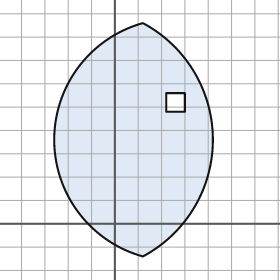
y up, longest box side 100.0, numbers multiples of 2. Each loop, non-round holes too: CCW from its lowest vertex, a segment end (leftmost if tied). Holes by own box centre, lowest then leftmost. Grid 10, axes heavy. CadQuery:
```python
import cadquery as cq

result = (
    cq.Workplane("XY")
    .moveTo(12.0, -14.0)
    .threePointArc((42.0, 36.0), (12.0, 86.0))
    .threePointArc((-26.0, 36.0), (12.0, -14.0))
    .close()
    .moveTo(22.0, 48.0)
    .lineTo(30.0, 48.0)
    .lineTo(30.0, 56.0)
    .lineTo(22.0, 56.0)
    .close()
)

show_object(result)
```